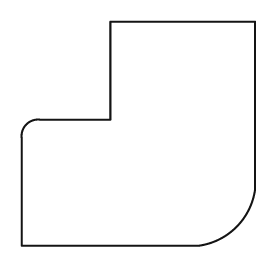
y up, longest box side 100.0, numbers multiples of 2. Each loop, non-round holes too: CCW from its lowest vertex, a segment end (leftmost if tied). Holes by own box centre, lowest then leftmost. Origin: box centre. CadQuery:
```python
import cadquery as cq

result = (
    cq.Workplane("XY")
    .moveTo(-50.0, -48.0)
    .lineTo(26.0, -48.0)
    .threePointArc((42.0, -40.0), (50.0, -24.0))
    .lineTo(50.0, 48.0)
    .lineTo(-12.0, 48.0)
    .lineTo(-12.0, 6.0)
    .lineTo(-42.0, 6.0)
    .threePointArc((-48.0, 4.0), (-50.0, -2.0))
    .close()
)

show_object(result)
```